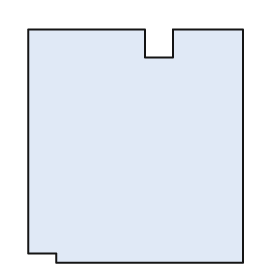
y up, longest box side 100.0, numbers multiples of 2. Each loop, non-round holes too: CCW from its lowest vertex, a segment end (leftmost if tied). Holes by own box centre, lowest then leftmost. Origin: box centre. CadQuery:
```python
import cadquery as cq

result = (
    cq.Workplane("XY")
    .moveTo(-34.0, -50.0)
    .lineTo(46.0, -50.0)
    .lineTo(46.0, 50.0)
    .lineTo(16.0, 50.0)
    .lineTo(16.0, 38.0)
    .lineTo(4.0, 38.0)
    .lineTo(4.0, 50.0)
    .lineTo(-46.0, 50.0)
    .lineTo(-46.0, -46.0)
    .lineTo(-34.0, -46.0)
    .close()
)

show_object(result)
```